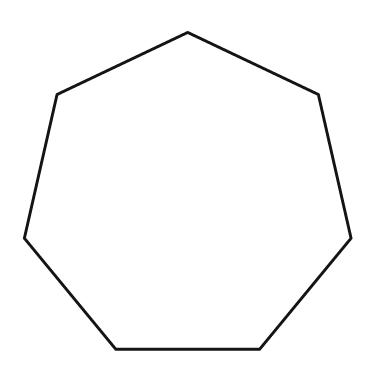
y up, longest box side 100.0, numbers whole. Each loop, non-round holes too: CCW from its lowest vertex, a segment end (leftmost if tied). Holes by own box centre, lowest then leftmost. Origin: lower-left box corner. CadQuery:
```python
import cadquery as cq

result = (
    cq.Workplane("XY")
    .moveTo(28.0, 0.0)
    .lineTo(72.0, 0.0)
    .lineTo(100.0, 34.0)
    .lineTo(90.0, 78.0)
    .lineTo(50.0, 97.0)
    .lineTo(10.0, 78.0)
    .lineTo(0.0, 34.0)
    .close()
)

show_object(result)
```